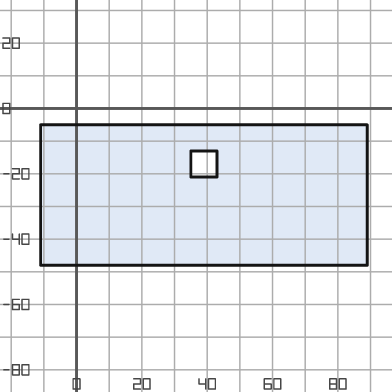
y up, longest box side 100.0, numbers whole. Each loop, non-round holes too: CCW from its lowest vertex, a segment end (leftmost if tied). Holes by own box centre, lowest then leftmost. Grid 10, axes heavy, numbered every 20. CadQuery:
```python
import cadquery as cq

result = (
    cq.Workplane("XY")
    .moveTo(-11.0, -48.0)
    .lineTo(89.0, -48.0)
    .lineTo(89.0, -5.0)
    .lineTo(-11.0, -5.0)
    .close()
    .moveTo(35.0, -21.0)
    .lineTo(43.0, -21.0)
    .lineTo(43.0, -13.0)
    .lineTo(35.0, -13.0)
    .close()
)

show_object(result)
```